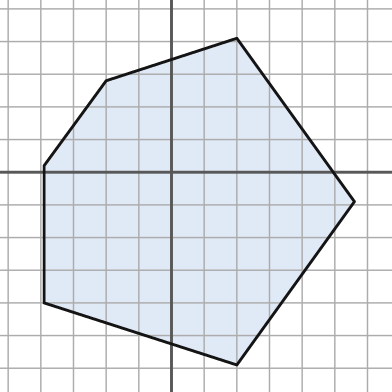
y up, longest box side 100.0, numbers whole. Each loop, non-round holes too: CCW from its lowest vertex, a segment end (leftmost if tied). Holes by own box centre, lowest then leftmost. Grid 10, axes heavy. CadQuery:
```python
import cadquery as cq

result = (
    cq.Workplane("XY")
    .moveTo(20.0, -59.0)
    .lineTo(56.0, -9.0)
    .lineTo(20.0, 41.0)
    .lineTo(-20.0, 28.0)
    .lineTo(-39.0, 2.0)
    .lineTo(-39.0, -40.0)
    .close()
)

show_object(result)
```